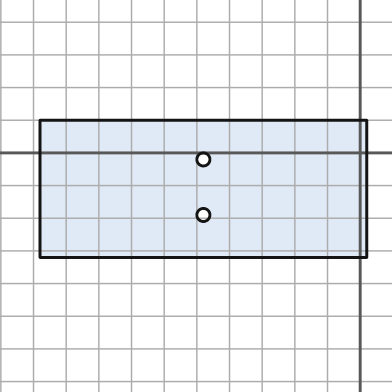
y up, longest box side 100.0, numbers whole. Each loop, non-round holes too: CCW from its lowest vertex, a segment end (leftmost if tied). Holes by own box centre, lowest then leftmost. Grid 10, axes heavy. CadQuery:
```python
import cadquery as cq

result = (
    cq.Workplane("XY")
    .moveTo(-98.0, -32.0)
    .lineTo(2.0, -32.0)
    .lineTo(2.0, 10.0)
    .lineTo(-98.0, 10.0)
    .close()
    .moveTo(-48.0, -19.0)
    .circle(2.0)
    .moveTo(-48.0, -2.0)
    .circle(2.0)
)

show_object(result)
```